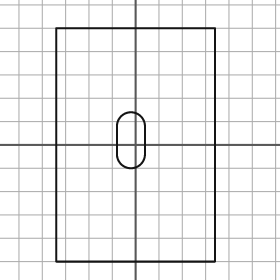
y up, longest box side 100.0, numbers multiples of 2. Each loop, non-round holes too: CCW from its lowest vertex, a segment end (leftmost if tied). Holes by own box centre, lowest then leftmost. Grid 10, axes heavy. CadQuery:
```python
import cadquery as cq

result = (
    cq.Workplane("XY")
    .moveTo(-34.0, -50.0)
    .lineTo(34.0, -50.0)
    .lineTo(34.0, 50.0)
    .lineTo(-34.0, 50.0)
    .close()
    .moveTo(-8.0, -4.0)
    .threePointArc((-2.0, -10.0), (4.0, -4.0))
    .lineTo(4.0, 8.0)
    .threePointArc((-2.0, 14.0), (-8.0, 8.0))
    .close()
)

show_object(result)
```